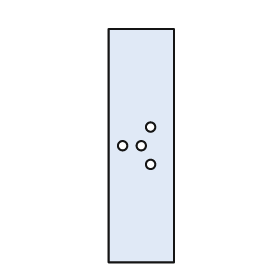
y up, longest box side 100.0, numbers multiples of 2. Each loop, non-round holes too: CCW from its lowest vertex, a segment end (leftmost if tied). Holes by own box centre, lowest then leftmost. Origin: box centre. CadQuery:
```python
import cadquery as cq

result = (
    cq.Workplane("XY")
    .moveTo(-14.0, -50.0)
    .lineTo(14.0, -50.0)
    .lineTo(14.0, 50.0)
    .lineTo(-14.0, 50.0)
    .close()
    .moveTo(4.0, -8.0)
    .circle(2.0)
    .moveTo(-8.0, 0.0)
    .circle(2.0)
    .moveTo(0.0, 0.0)
    .circle(2.0)
    .moveTo(4.0, 8.0)
    .circle(2.0)
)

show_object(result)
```